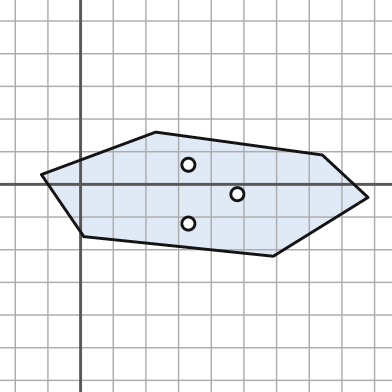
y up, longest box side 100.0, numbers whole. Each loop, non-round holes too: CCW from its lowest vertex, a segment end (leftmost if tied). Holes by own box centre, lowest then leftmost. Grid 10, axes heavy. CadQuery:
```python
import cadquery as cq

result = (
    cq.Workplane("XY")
    .moveTo(59.0, -22.0)
    .lineTo(88.0, -4.0)
    .lineTo(74.0, 9.0)
    .lineTo(23.0, 16.0)
    .lineTo(-12.0, 3.0)
    .lineTo(1.0, -16.0)
    .close()
    .moveTo(33.0, -12.0)
    .circle(2.0)
    .moveTo(48.0, -3.0)
    .circle(2.0)
    .moveTo(33.0, 6.0)
    .circle(2.0)
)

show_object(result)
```